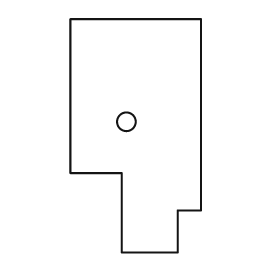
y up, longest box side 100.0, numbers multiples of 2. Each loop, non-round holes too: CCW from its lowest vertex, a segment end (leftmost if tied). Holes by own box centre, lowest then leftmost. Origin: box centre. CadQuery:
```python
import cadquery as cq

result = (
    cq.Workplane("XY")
    .moveTo(-6.0, -50.0)
    .lineTo(18.0, -50.0)
    .lineTo(18.0, -32.0)
    .lineTo(28.0, -32.0)
    .lineTo(28.0, 50.0)
    .lineTo(-28.0, 50.0)
    .lineTo(-28.0, -16.0)
    .lineTo(-6.0, -16.0)
    .close()
    .moveTo(-4.0, 6.0)
    .circle(4.0)
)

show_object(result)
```